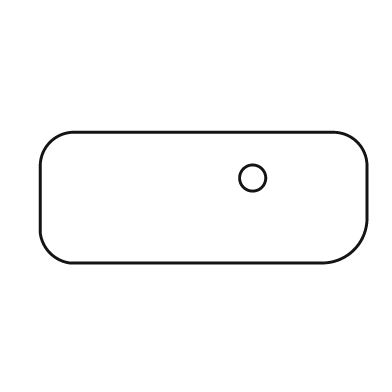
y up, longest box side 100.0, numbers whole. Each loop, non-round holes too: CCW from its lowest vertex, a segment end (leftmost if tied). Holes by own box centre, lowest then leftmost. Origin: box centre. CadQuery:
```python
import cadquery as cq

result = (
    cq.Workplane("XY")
    .moveTo(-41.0, -20.0)
    .lineTo(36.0, -20.0)
    .threePointArc((46.0, -16.0), (50.0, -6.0))
    .lineTo(50.0, 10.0)
    .threePointArc((47.0, 17.0), (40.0, 20.0))
    .lineTo(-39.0, 20.0)
    .threePointArc((-47.0, 17.0), (-50.0, 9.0))
    .lineTo(-50.0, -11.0)
    .threePointArc((-47.0, -17.0), (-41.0, -20.0))
    .close()
    .moveTo(15.0, 6.0)
    .circle(4.0)
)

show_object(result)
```